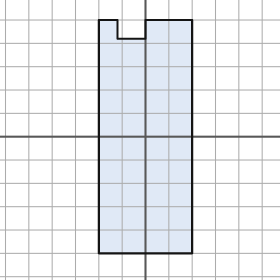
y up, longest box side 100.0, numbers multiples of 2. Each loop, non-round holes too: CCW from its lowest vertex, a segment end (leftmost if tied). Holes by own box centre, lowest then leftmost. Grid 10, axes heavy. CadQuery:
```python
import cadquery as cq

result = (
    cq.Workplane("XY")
    .moveTo(-20.0, -50.0)
    .lineTo(20.0, -50.0)
    .lineTo(20.0, 50.0)
    .lineTo(0.0, 50.0)
    .lineTo(0.0, 42.0)
    .lineTo(-12.0, 42.0)
    .lineTo(-12.0, 50.0)
    .lineTo(-20.0, 50.0)
    .close()
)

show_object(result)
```